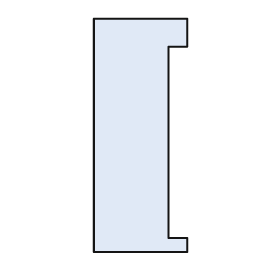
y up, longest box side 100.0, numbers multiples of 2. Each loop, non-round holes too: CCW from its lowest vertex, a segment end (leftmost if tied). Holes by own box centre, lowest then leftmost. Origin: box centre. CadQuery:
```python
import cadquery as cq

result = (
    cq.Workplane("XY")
    .moveTo(-20.0, -50.0)
    .lineTo(20.0, -50.0)
    .lineTo(20.0, -44.0)
    .lineTo(12.0, -44.0)
    .lineTo(12.0, 38.0)
    .lineTo(20.0, 38.0)
    .lineTo(20.0, 50.0)
    .lineTo(-20.0, 50.0)
    .close()
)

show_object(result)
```